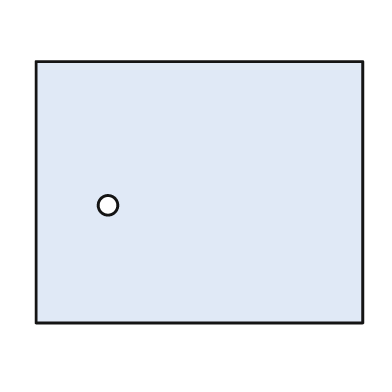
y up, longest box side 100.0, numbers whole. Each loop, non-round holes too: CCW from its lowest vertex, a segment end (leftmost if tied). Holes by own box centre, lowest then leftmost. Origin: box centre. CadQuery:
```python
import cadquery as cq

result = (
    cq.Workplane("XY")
    .moveTo(-50.0, -40.0)
    .lineTo(50.0, -40.0)
    .lineTo(50.0, 40.0)
    .lineTo(-50.0, 40.0)
    .close()
    .moveTo(-28.0, -4.0)
    .circle(3.0)
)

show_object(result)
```